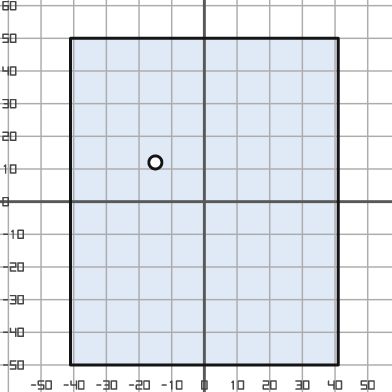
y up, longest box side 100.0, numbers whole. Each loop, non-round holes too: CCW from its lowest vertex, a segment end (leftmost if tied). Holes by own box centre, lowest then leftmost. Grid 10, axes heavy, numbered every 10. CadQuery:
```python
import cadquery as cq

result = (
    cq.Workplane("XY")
    .moveTo(-41.0, -50.0)
    .lineTo(41.0, -50.0)
    .lineTo(41.0, 50.0)
    .lineTo(-41.0, 50.0)
    .close()
    .moveTo(-15.0, 12.0)
    .circle(2.0)
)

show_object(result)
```